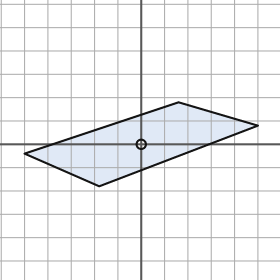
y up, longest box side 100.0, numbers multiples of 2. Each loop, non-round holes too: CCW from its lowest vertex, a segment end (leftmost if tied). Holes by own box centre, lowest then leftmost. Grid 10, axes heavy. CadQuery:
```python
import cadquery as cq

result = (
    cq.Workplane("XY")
    .moveTo(-18.0, -18.0)
    .lineTo(50.0, 8.0)
    .lineTo(16.0, 18.0)
    .lineTo(-50.0, -4.0)
    .close()
    .moveTo(0.0, 0.0)
    .circle(2.0)
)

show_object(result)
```